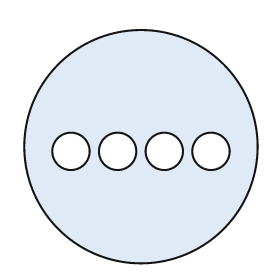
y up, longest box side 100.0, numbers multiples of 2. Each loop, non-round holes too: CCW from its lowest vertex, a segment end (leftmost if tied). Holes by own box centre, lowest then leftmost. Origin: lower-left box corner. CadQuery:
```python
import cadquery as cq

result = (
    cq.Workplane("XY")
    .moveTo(50.0, 50.0)
    .circle(50.0)
    .moveTo(20.0, 48.0)
    .circle(8.0)
    .moveTo(40.0, 48.0)
    .circle(8.0)
    .moveTo(60.0, 48.0)
    .circle(8.0)
    .moveTo(80.0, 48.0)
    .circle(8.0)
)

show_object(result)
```